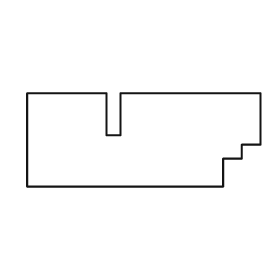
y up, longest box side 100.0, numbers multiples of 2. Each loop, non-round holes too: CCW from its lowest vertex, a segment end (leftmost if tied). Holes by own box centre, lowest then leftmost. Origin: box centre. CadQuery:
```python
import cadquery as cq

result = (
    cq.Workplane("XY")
    .moveTo(-50.0, -20.0)
    .lineTo(34.0, -20.0)
    .lineTo(34.0, -8.0)
    .lineTo(42.0, -8.0)
    .lineTo(42.0, -2.0)
    .lineTo(50.0, -2.0)
    .lineTo(50.0, 20.0)
    .lineTo(-10.0, 20.0)
    .lineTo(-10.0, 2.0)
    .lineTo(-16.0, 2.0)
    .lineTo(-16.0, 20.0)
    .lineTo(-50.0, 20.0)
    .close()
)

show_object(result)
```